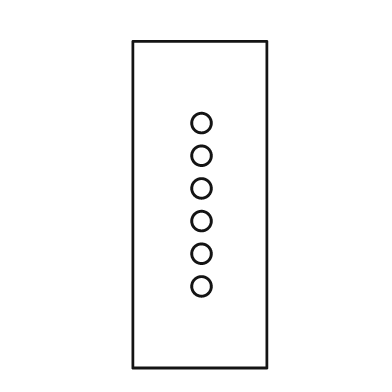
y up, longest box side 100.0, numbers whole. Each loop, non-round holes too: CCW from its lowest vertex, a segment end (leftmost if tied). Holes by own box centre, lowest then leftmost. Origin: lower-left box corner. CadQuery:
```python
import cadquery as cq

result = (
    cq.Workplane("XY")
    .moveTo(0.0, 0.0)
    .lineTo(41.0, 0.0)
    .lineTo(41.0, 100.0)
    .lineTo(0.0, 100.0)
    .close()
    .moveTo(21.0, 25.0)
    .circle(3.0)
    .moveTo(21.0, 35.0)
    .circle(3.0)
    .moveTo(21.0, 45.0)
    .circle(3.0)
    .moveTo(21.0, 55.0)
    .circle(3.0)
    .moveTo(21.0, 65.0)
    .circle(3.0)
    .moveTo(21.0, 75.0)
    .circle(3.0)
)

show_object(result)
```